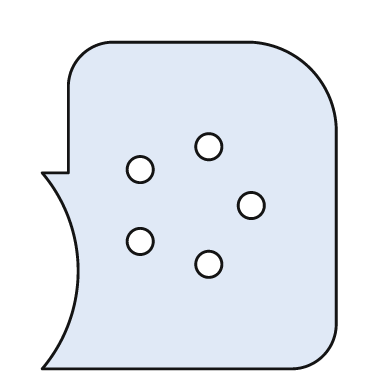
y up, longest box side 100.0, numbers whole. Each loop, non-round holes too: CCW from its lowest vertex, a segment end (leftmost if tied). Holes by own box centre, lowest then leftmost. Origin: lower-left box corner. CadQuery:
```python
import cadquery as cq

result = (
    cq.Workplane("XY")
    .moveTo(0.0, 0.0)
    .lineTo(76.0, 0.0)
    .threePointArc((86.0, 4.0), (90.0, 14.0))
    .lineTo(90.0, 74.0)
    .threePointArc((82.0, 92.0), (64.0, 100.0))
    .lineTo(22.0, 100.0)
    .threePointArc((12.0, 96.0), (8.0, 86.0))
    .lineTo(8.0, 60.0)
    .lineTo(0.0, 60.0)
    .threePointArc((11.0, 30.0), (0.0, 0.0))
    .close()
    .moveTo(51.0, 32.0)
    .circle(4.0)
    .moveTo(30.0, 39.0)
    .circle(4.0)
    .moveTo(64.0, 50.0)
    .circle(4.0)
    .moveTo(30.0, 61.0)
    .circle(4.0)
    .moveTo(51.0, 68.0)
    .circle(4.0)
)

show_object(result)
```